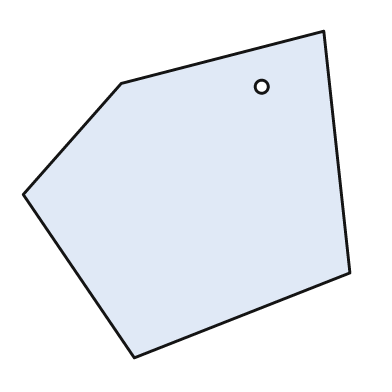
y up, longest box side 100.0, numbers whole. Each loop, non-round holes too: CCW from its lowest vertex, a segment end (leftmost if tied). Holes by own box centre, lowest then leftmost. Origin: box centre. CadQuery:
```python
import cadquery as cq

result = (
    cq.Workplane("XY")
    .moveTo(-16.0, -50.0)
    .lineTo(50.0, -24.0)
    .lineTo(42.0, 50.0)
    .lineTo(-20.0, 34.0)
    .lineTo(-50.0, 0.0)
    .close()
    .moveTo(23.0, 33.0)
    .circle(2.0)
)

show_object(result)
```